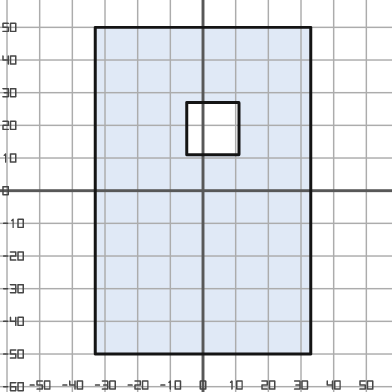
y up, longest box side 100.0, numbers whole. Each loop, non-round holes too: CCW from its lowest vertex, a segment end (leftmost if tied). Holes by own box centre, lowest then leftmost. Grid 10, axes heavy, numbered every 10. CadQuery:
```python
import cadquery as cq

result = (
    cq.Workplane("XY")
    .moveTo(-33.0, -50.0)
    .lineTo(33.0, -50.0)
    .lineTo(33.0, 50.0)
    .lineTo(-33.0, 50.0)
    .close()
    .moveTo(-5.0, 11.0)
    .lineTo(11.0, 11.0)
    .lineTo(11.0, 27.0)
    .lineTo(-5.0, 27.0)
    .close()
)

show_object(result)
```